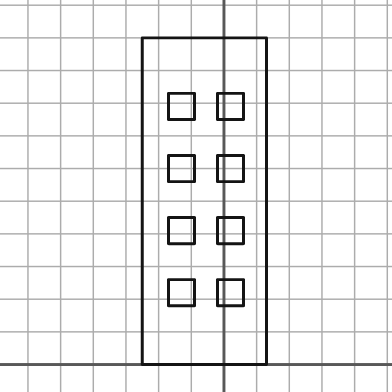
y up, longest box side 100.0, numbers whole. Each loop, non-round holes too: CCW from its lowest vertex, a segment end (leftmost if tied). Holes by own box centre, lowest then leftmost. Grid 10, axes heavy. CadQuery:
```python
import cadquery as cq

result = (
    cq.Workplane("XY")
    .moveTo(-25.0, 0.0)
    .lineTo(13.0, 0.0)
    .lineTo(13.0, 100.0)
    .lineTo(-25.0, 100.0)
    .close()
    .moveTo(-17.0, 18.0)
    .lineTo(-9.0, 18.0)
    .lineTo(-9.0, 26.0)
    .lineTo(-17.0, 26.0)
    .close()
    .moveTo(-2.0, 18.0)
    .lineTo(6.0, 18.0)
    .lineTo(6.0, 26.0)
    .lineTo(-2.0, 26.0)
    .close()
    .moveTo(-17.0, 37.0)
    .lineTo(-9.0, 37.0)
    .lineTo(-9.0, 45.0)
    .lineTo(-17.0, 45.0)
    .close()
    .moveTo(-2.0, 37.0)
    .lineTo(6.0, 37.0)
    .lineTo(6.0, 45.0)
    .lineTo(-2.0, 45.0)
    .close()
    .moveTo(-17.0, 56.0)
    .lineTo(-9.0, 56.0)
    .lineTo(-9.0, 64.0)
    .lineTo(-17.0, 64.0)
    .close()
    .moveTo(-2.0, 56.0)
    .lineTo(6.0, 56.0)
    .lineTo(6.0, 64.0)
    .lineTo(-2.0, 64.0)
    .close()
    .moveTo(-17.0, 75.0)
    .lineTo(-9.0, 75.0)
    .lineTo(-9.0, 83.0)
    .lineTo(-17.0, 83.0)
    .close()
    .moveTo(-2.0, 75.0)
    .lineTo(6.0, 75.0)
    .lineTo(6.0, 83.0)
    .lineTo(-2.0, 83.0)
    .close()
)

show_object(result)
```